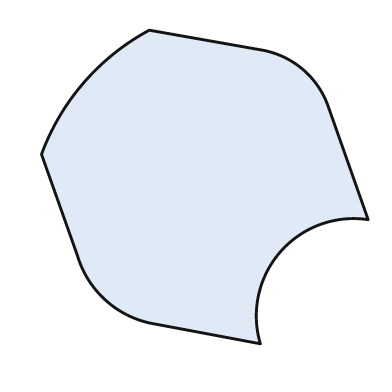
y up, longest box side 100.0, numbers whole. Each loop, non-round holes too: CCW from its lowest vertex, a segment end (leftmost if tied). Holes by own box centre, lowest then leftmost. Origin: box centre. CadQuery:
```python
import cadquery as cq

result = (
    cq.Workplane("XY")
    .moveTo(17.0, -48.0)
    .threePointArc((23.0, -20.0), (50.0, -10.0))
    .lineTo(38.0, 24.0)
    .threePointArc((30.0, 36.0), (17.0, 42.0))
    .lineTo(-17.0, 48.0)
    .threePointArc((-37.0, 32.0), (-50.0, 10.0))
    .lineTo(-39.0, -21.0)
    .threePointArc((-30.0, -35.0), (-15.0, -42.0))
    .close()
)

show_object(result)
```